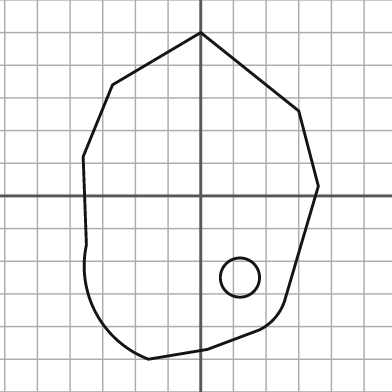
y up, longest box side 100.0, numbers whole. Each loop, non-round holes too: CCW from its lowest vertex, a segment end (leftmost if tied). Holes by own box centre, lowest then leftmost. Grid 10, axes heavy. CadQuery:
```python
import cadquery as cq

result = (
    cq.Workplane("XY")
    .moveTo(-16.0, -50.0)
    .lineTo(2.0, -47.0)
    .lineTo(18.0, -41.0)
    .threePointArc((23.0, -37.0), (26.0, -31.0))
    .lineTo(36.0, 3.0)
    .lineTo(30.0, 26.0)
    .lineTo(0.0, 50.0)
    .lineTo(-27.0, 34.0)
    .lineTo(-36.0, 12.0)
    .lineTo(-35.0, -15.0)
    .threePointArc((-32.0, -36.0), (-16.0, -50.0))
    .close()
    .moveTo(12.0, -25.0)
    .circle(6.0)
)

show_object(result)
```